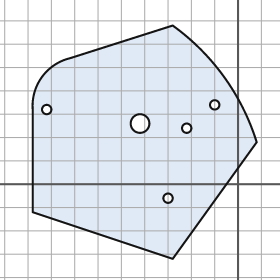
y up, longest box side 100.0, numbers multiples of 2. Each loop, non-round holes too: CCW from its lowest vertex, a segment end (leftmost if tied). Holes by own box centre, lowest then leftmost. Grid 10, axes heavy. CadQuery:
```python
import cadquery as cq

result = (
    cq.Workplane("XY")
    .moveTo(-28.0, -32.0)
    .lineTo(8.0, 18.0)
    .threePointArc((-6.0, 46.0), (-28.0, 68.0))
    .lineTo(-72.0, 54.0)
    .threePointArc((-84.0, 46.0), (-88.0, 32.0))
    .lineTo(-88.0, -12.0)
    .close()
    .moveTo(-30.0, -6.0)
    .circle(2.0)
    .moveTo(-22.0, 24.0)
    .circle(2.0)
    .moveTo(-42.0, 26.0)
    .circle(4.0)
    .moveTo(-82.0, 32.0)
    .circle(2.0)
    .moveTo(-10.0, 34.0)
    .circle(2.0)
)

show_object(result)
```